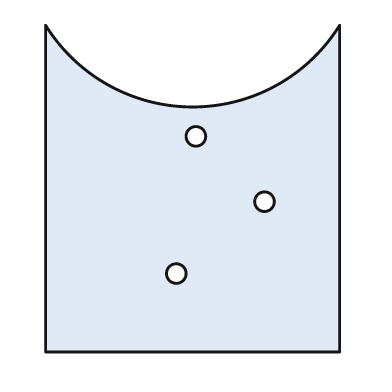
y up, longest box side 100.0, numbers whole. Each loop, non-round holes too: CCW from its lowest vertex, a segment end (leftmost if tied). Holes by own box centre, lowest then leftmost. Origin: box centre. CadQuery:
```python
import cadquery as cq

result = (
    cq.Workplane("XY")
    .moveTo(-45.0, -50.0)
    .lineTo(45.0, -50.0)
    .lineTo(45.0, 50.0)
    .threePointArc((0.0, 25.0), (-45.0, 50.0))
    .close()
    .moveTo(-5.0, -26.0)
    .circle(3.0)
    .moveTo(22.0, -4.0)
    .circle(3.0)
    .moveTo(1.0, 16.0)
    .circle(3.0)
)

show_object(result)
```